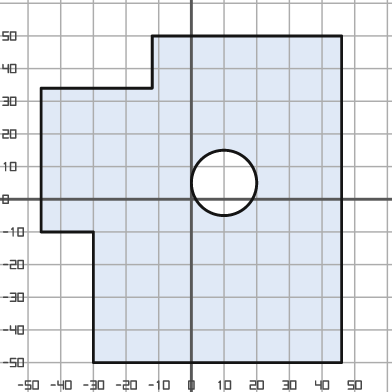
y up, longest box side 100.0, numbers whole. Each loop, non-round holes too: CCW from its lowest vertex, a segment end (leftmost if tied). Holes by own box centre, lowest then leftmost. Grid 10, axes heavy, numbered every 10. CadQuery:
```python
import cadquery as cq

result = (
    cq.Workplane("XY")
    .moveTo(-30.0, -50.0)
    .lineTo(46.0, -50.0)
    .lineTo(46.0, 50.0)
    .lineTo(-12.0, 50.0)
    .lineTo(-12.0, 34.0)
    .lineTo(-46.0, 34.0)
    .lineTo(-46.0, -10.0)
    .lineTo(-30.0, -10.0)
    .close()
    .moveTo(10.0, 5.0)
    .circle(10.0)
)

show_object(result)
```